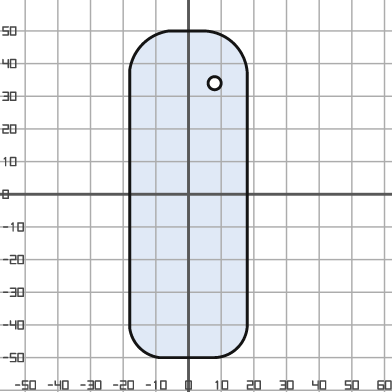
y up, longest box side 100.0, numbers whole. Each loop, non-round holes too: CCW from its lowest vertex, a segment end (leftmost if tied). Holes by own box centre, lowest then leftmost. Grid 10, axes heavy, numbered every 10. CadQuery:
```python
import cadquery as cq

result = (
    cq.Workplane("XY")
    .moveTo(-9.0, -50.0)
    .lineTo(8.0, -50.0)
    .threePointArc((15.0, -47.0), (18.0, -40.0))
    .lineTo(18.0, 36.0)
    .threePointArc((14.0, 46.0), (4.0, 50.0))
    .lineTo(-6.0, 50.0)
    .threePointArc((-14.0, 46.0), (-18.0, 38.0))
    .lineTo(-18.0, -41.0)
    .threePointArc((-15.0, -47.0), (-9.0, -50.0))
    .close()
    .moveTo(8.0, 34.0)
    .circle(2.0)
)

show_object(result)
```